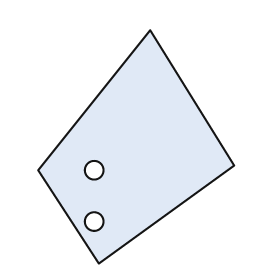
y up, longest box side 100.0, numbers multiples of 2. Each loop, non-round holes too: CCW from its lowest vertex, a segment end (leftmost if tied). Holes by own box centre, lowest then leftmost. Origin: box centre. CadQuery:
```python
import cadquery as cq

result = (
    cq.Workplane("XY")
    .moveTo(-16.0, -50.0)
    .lineTo(42.0, -8.0)
    .lineTo(6.0, 50.0)
    .lineTo(-42.0, -10.0)
    .close()
    .moveTo(-18.0, -32.0)
    .circle(4.0)
    .moveTo(-18.0, -10.0)
    .circle(4.0)
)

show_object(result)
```